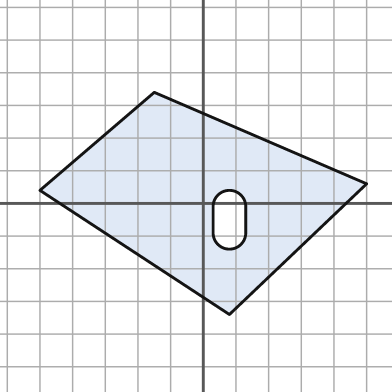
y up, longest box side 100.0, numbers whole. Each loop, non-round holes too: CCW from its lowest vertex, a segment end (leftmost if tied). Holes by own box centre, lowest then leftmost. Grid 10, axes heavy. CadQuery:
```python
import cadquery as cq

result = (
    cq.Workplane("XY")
    .moveTo(8.0, -34.0)
    .lineTo(50.0, 6.0)
    .lineTo(-15.0, 34.0)
    .lineTo(-50.0, 4.0)
    .close()
    .moveTo(3.0, -9.0)
    .threePointArc((8.0, -14.0), (13.0, -9.0))
    .lineTo(13.0, -1.0)
    .threePointArc((8.0, 4.0), (3.0, -1.0))
    .close()
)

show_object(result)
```